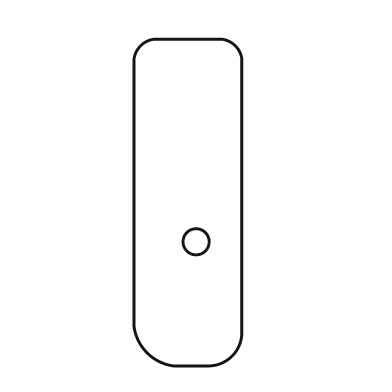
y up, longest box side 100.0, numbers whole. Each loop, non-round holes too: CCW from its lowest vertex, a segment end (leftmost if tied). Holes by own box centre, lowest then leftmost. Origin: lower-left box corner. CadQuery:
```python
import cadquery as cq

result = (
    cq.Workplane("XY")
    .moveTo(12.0, 0.0)
    .lineTo(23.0, 0.0)
    .threePointArc((30.0, 3.0), (33.0, 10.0))
    .lineTo(33.0, 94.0)
    .threePointArc((31.0, 98.0), (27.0, 100.0))
    .lineTo(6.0, 100.0)
    .threePointArc((2.0, 98.0), (0.0, 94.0))
    .lineTo(0.0, 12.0)
    .threePointArc((4.0, 4.0), (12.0, 0.0))
    .close()
    .moveTo(19.0, 38.0)
    .circle(4.0)
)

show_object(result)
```